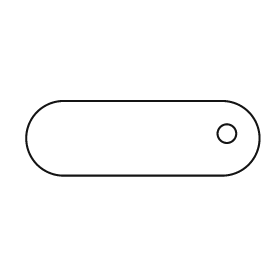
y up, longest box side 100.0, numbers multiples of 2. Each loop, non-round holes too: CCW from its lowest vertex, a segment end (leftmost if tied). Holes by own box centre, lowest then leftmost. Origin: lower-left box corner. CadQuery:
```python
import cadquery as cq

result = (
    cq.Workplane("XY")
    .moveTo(16.0, 0.0)
    .lineTo(84.0, 0.0)
    .threePointArc((100.0, 16.0), (84.0, 32.0))
    .lineTo(16.0, 32.0)
    .threePointArc((0.0, 16.0), (16.0, 0.0))
    .close()
    .moveTo(86.0, 18.0)
    .circle(4.0)
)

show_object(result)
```